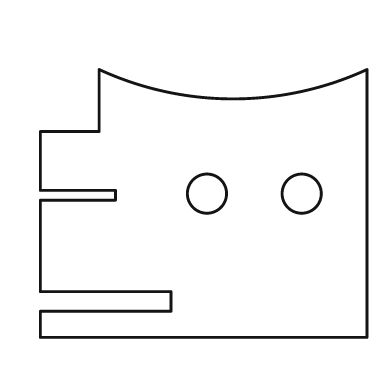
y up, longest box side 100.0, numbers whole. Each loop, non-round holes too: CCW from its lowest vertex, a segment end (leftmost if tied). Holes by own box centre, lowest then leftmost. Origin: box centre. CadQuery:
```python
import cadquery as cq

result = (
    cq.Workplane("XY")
    .moveTo(-50.0, -41.0)
    .lineTo(50.0, -41.0)
    .lineTo(50.0, 41.0)
    .threePointArc((9.0, 32.0), (-32.0, 41.0))
    .lineTo(-32.0, 22.0)
    .lineTo(-50.0, 22.0)
    .lineTo(-50.0, 4.0)
    .lineTo(-27.0, 4.0)
    .lineTo(-27.0, 1.0)
    .lineTo(-50.0, 1.0)
    .lineTo(-50.0, -27.0)
    .lineTo(-10.0, -27.0)
    .lineTo(-10.0, -33.0)
    .lineTo(-50.0, -33.0)
    .close()
    .moveTo(1.0, 3.0)
    .circle(6.0)
    .moveTo(30.0, 3.0)
    .circle(6.0)
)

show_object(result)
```